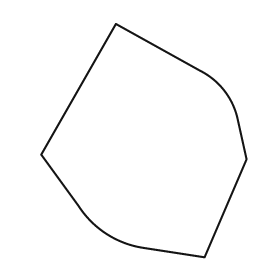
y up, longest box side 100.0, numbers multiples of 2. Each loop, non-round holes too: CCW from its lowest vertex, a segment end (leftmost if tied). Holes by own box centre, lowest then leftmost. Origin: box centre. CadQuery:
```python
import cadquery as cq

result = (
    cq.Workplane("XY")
    .moveTo(26.0, -50.0)
    .lineTo(44.0, -8.0)
    .lineTo(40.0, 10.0)
    .threePointArc((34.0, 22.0), (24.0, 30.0))
    .lineTo(-12.0, 50.0)
    .lineTo(-44.0, -6.0)
    .lineTo(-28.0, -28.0)
    .threePointArc((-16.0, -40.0), (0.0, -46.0))
    .close()
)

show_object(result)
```